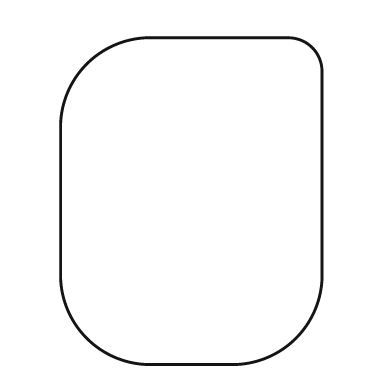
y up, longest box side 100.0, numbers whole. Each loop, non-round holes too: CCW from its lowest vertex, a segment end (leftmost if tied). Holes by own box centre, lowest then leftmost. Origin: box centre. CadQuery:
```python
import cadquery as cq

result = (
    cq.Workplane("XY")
    .moveTo(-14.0, -50.0)
    .lineTo(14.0, -50.0)
    .threePointArc((32.0, -42.0), (40.0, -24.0))
    .lineTo(40.0, 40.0)
    .threePointArc((37.0, 47.0), (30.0, 50.0))
    .lineTo(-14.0, 50.0)
    .threePointArc((-32.0, 42.0), (-40.0, 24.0))
    .lineTo(-40.0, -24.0)
    .threePointArc((-32.0, -42.0), (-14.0, -50.0))
    .close()
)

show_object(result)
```